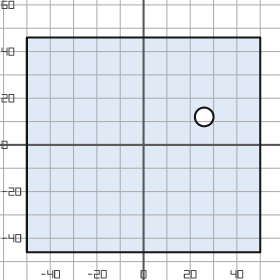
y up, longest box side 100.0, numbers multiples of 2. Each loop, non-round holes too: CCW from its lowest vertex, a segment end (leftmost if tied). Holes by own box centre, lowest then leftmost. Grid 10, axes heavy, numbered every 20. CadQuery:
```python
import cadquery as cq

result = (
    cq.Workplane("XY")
    .moveTo(-50.0, -46.0)
    .lineTo(50.0, -46.0)
    .lineTo(50.0, 46.0)
    .lineTo(-50.0, 46.0)
    .close()
    .moveTo(26.0, 12.0)
    .circle(4.0)
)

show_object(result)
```